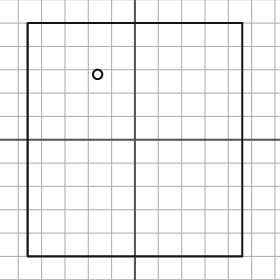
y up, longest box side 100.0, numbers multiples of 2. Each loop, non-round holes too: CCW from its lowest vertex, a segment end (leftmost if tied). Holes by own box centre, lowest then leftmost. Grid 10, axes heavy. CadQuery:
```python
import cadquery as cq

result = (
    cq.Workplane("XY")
    .moveTo(-46.0, -50.0)
    .lineTo(46.0, -50.0)
    .lineTo(46.0, 50.0)
    .lineTo(-46.0, 50.0)
    .close()
    .moveTo(-16.0, 28.0)
    .circle(2.0)
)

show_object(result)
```